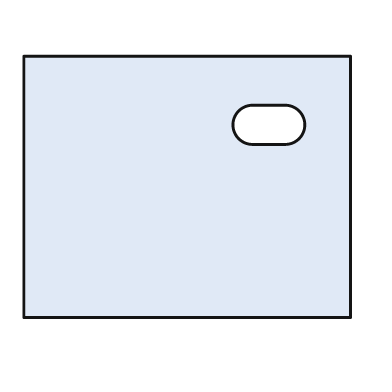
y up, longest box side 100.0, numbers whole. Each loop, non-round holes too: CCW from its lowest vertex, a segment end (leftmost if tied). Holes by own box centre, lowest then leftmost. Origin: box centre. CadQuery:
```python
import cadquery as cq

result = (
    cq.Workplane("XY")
    .moveTo(-50.0, -40.0)
    .lineTo(50.0, -40.0)
    .lineTo(50.0, 40.0)
    .lineTo(-50.0, 40.0)
    .close()
    .moveTo(20.0, 13.0)
    .lineTo(30.0, 13.0)
    .threePointArc((36.0, 19.0), (30.0, 25.0))
    .lineTo(20.0, 25.0)
    .threePointArc((14.0, 19.0), (20.0, 13.0))
    .close()
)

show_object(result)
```